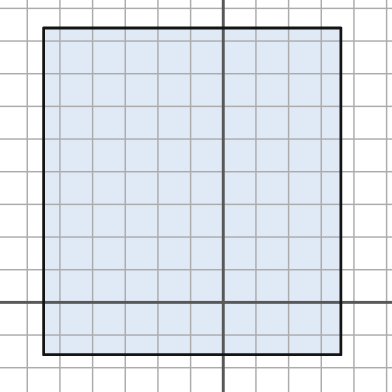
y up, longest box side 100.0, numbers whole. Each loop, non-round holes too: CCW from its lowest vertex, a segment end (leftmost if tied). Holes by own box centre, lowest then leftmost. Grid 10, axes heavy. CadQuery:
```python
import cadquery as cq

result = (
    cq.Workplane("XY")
    .moveTo(-55.0, -16.0)
    .lineTo(36.0, -16.0)
    .lineTo(36.0, 84.0)
    .lineTo(-55.0, 84.0)
    .close()
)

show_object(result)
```